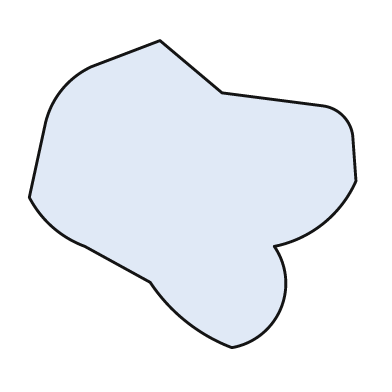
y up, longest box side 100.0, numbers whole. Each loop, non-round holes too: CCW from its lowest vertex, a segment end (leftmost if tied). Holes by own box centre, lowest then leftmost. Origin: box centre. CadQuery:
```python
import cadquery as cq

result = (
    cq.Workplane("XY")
    .moveTo(12.0, -47.0)
    .threePointArc((27.0, -35.0), (25.0, -16.0))
    .threePointArc((40.0, -9.0), (50.0, 4.0))
    .lineTo(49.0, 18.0)
    .threePointArc((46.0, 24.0), (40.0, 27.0))
    .lineTo(9.0, 31.0)
    .lineTo(-10.0, 47.0)
    .lineTo(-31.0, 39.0)
    .threePointArc((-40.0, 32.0), (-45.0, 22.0))
    .lineTo(-50.0, -1.0)
    .threePointArc((-43.0, -10.0), (-33.0, -16.0))
    .lineTo(-13.0, -27.0)
    .threePointArc((-2.0, -39.0), (12.0, -47.0))
    .close()
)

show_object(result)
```